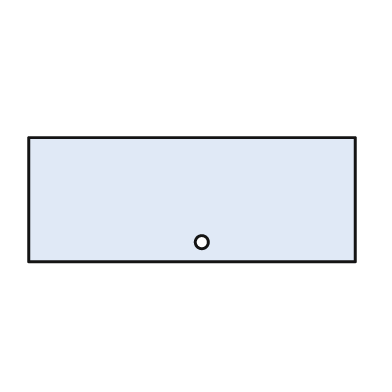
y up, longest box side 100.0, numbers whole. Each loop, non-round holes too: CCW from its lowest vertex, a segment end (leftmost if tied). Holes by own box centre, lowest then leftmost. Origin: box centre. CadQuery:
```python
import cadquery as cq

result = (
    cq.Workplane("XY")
    .moveTo(-50.0, -19.0)
    .lineTo(50.0, -19.0)
    .lineTo(50.0, 19.0)
    .lineTo(-50.0, 19.0)
    .close()
    .moveTo(3.0, -13.0)
    .circle(2.0)
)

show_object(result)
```